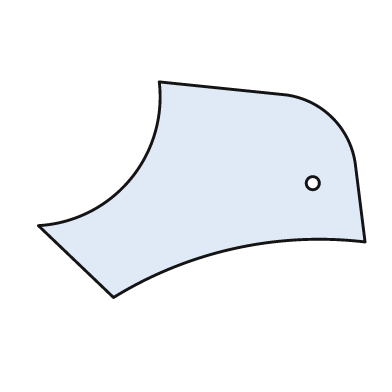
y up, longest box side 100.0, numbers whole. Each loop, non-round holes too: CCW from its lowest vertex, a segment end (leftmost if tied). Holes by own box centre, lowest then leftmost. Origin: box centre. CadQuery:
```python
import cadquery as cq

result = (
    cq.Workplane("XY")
    .moveTo(-27.0, -33.0)
    .threePointArc((10.0, -18.0), (50.0, -16.0))
    .lineTo(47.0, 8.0)
    .threePointArc((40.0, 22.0), (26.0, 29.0))
    .lineTo(-13.0, 33.0)
    .threePointArc((-22.0, 3.0), (-50.0, -11.0))
    .close()
    .moveTo(34.0, 2.0)
    .circle(2.0)
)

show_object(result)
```